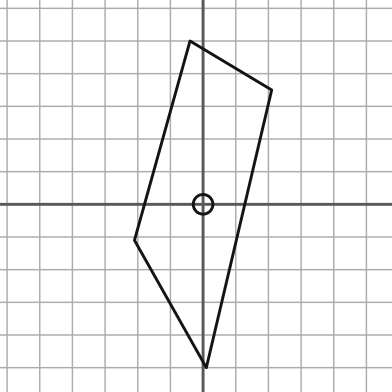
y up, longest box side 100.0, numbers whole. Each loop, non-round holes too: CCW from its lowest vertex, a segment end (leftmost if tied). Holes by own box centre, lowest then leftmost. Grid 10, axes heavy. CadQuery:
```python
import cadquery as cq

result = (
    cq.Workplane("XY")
    .moveTo(1.0, -50.0)
    .lineTo(21.0, 35.0)
    .lineTo(-4.0, 50.0)
    .lineTo(-21.0, -11.0)
    .close()
    .moveTo(0.0, 0.0)
    .circle(3.0)
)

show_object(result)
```